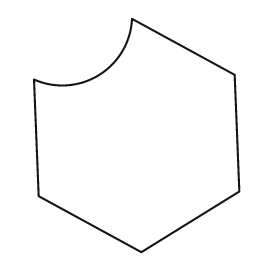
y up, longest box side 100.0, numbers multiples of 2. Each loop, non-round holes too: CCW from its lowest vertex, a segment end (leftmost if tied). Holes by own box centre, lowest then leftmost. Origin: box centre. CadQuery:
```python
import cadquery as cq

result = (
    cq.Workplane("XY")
    .moveTo(2.0, -50.0)
    .lineTo(44.0, -24.0)
    .lineTo(42.0, 26.0)
    .lineTo(-2.0, 50.0)
    .threePointArc((-16.0, 26.0), (-44.0, 24.0))
    .lineTo(-42.0, -26.0)
    .close()
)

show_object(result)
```